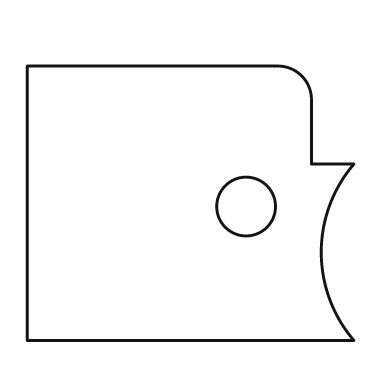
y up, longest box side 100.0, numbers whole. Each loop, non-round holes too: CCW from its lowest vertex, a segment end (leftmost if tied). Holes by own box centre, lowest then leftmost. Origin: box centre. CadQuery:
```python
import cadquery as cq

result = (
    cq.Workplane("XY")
    .moveTo(-50.0, -42.0)
    .lineTo(50.0, -42.0)
    .threePointArc((40.0, -15.0), (50.0, 12.0))
    .lineTo(37.0, 12.0)
    .lineTo(37.0, 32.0)
    .threePointArc((34.0, 39.0), (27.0, 42.0))
    .lineTo(-50.0, 42.0)
    .close()
    .moveTo(17.0, -1.0)
    .circle(9.0)
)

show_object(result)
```